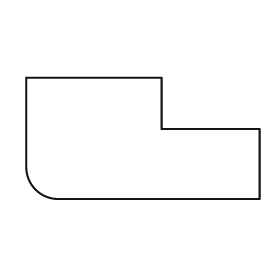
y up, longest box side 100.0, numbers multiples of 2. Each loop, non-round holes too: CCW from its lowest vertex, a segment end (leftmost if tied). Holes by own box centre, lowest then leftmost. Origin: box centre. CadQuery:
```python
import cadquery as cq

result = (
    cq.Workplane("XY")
    .moveTo(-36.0, -26.0)
    .lineTo(50.0, -26.0)
    .lineTo(50.0, 4.0)
    .lineTo(8.0, 4.0)
    .lineTo(8.0, 26.0)
    .lineTo(-50.0, 26.0)
    .lineTo(-50.0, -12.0)
    .threePointArc((-46.0, -22.0), (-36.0, -26.0))
    .close()
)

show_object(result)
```